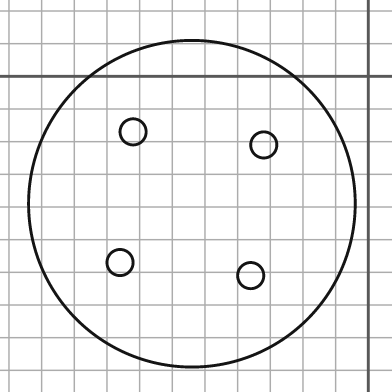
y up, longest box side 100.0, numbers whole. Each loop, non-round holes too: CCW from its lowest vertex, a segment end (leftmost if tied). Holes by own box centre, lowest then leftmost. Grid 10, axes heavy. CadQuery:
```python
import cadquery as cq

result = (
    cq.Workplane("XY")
    .moveTo(-54.0, -39.0)
    .circle(50.0)
    .moveTo(-36.0, -61.0)
    .circle(4.0)
    .moveTo(-76.0, -57.0)
    .circle(4.0)
    .moveTo(-32.0, -21.0)
    .circle(4.0)
    .moveTo(-72.0, -17.0)
    .circle(4.0)
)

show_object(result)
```